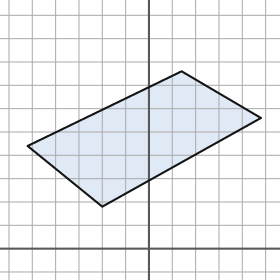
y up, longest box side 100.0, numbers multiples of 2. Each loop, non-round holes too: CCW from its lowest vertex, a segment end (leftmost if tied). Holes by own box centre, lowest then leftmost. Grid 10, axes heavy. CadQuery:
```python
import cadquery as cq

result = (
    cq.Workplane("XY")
    .moveTo(-20.0, 18.0)
    .lineTo(48.0, 56.0)
    .lineTo(14.0, 76.0)
    .lineTo(-52.0, 44.0)
    .close()
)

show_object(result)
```